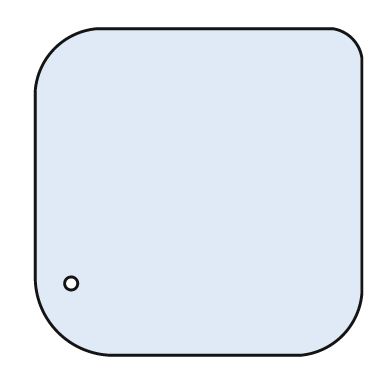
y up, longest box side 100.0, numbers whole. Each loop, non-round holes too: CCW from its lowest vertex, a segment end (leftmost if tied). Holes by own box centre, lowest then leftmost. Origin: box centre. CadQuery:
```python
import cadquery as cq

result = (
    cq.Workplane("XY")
    .moveTo(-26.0, -50.0)
    .lineTo(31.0, -50.0)
    .threePointArc((44.0, -44.0), (50.0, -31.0))
    .lineTo(50.0, 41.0)
    .threePointArc((47.0, 47.0), (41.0, 50.0))
    .lineTo(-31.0, 50.0)
    .threePointArc((-44.0, 44.0), (-50.0, 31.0))
    .lineTo(-50.0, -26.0)
    .threePointArc((-43.0, -43.0), (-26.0, -50.0))
    .close()
    .moveTo(-39.0, -28.0)
    .circle(2.0)
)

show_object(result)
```